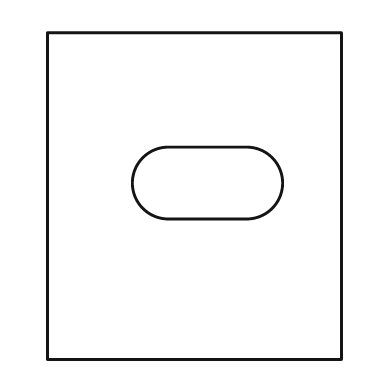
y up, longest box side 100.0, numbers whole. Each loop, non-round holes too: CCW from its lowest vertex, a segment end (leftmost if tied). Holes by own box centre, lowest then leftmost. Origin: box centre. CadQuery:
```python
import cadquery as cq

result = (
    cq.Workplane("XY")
    .moveTo(-45.0, -50.0)
    .lineTo(45.0, -50.0)
    .lineTo(45.0, 50.0)
    .lineTo(-45.0, 50.0)
    .close()
    .moveTo(-8.0, -7.0)
    .lineTo(16.0, -7.0)
    .threePointArc((27.0, 4.0), (16.0, 15.0))
    .lineTo(-8.0, 15.0)
    .threePointArc((-19.0, 4.0), (-8.0, -7.0))
    .close()
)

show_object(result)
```